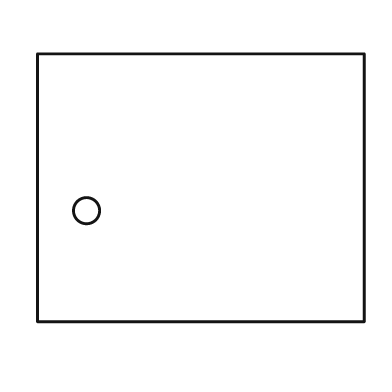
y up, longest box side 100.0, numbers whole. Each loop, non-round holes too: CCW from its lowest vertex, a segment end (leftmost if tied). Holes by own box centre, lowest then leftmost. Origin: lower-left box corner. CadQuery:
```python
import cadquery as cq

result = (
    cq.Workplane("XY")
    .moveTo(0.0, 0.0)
    .lineTo(100.0, 0.0)
    .lineTo(100.0, 82.0)
    .lineTo(0.0, 82.0)
    .close()
    .moveTo(15.0, 34.0)
    .circle(4.0)
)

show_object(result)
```